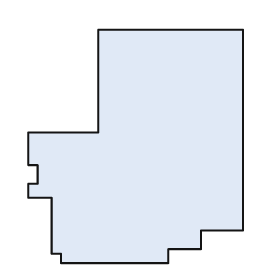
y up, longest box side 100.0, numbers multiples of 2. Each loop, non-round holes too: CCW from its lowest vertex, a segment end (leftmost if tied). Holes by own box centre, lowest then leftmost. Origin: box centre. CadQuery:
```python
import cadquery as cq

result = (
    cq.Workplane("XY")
    .moveTo(-32.0, -50.0)
    .lineTo(14.0, -50.0)
    .lineTo(14.0, -44.0)
    .lineTo(28.0, -44.0)
    .lineTo(28.0, -36.0)
    .lineTo(46.0, -36.0)
    .lineTo(46.0, 50.0)
    .lineTo(-16.0, 50.0)
    .lineTo(-16.0, 6.0)
    .lineTo(-46.0, 6.0)
    .lineTo(-46.0, -8.0)
    .lineTo(-42.0, -8.0)
    .lineTo(-42.0, -16.0)
    .lineTo(-46.0, -16.0)
    .lineTo(-46.0, -22.0)
    .lineTo(-36.0, -22.0)
    .lineTo(-36.0, -46.0)
    .lineTo(-32.0, -46.0)
    .close()
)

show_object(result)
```